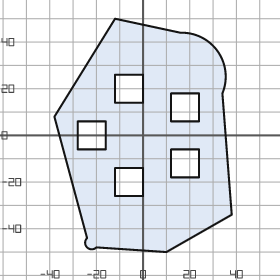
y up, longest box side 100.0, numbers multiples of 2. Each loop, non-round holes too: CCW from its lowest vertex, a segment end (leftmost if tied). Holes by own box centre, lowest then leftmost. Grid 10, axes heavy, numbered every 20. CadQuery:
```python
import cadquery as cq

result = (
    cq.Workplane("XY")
    .moveTo(10.0, -50.0)
    .lineTo(38.0, -34.0)
    .lineTo(34.0, 18.0)
    .threePointArc((32.0, 36.0), (16.0, 44.0))
    .lineTo(-12.0, 50.0)
    .lineTo(-38.0, 8.0)
    .lineTo(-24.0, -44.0)
    .threePointArc((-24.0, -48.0), (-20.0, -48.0))
    .close()
    .moveTo(-12.0, -26.0)
    .lineTo(0.0, -26.0)
    .lineTo(0.0, -14.0)
    .lineTo(-12.0, -14.0)
    .close()
    .moveTo(12.0, -18.0)
    .lineTo(24.0, -18.0)
    .lineTo(24.0, -6.0)
    .lineTo(12.0, -6.0)
    .close()
    .moveTo(-28.0, -6.0)
    .lineTo(-16.0, -6.0)
    .lineTo(-16.0, 6.0)
    .lineTo(-28.0, 6.0)
    .close()
    .moveTo(12.0, 6.0)
    .lineTo(24.0, 6.0)
    .lineTo(24.0, 18.0)
    .lineTo(12.0, 18.0)
    .close()
    .moveTo(-12.0, 14.0)
    .lineTo(0.0, 14.0)
    .lineTo(0.0, 26.0)
    .lineTo(-12.0, 26.0)
    .close()
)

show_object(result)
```